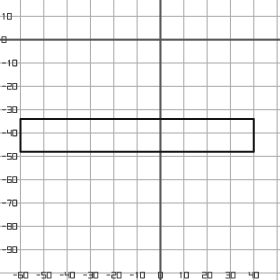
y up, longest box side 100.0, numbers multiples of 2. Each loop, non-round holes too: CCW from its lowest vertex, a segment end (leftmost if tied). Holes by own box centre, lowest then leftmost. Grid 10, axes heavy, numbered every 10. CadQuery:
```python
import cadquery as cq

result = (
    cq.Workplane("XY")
    .moveTo(-60.0, -48.0)
    .lineTo(40.0, -48.0)
    .lineTo(40.0, -34.0)
    .lineTo(-60.0, -34.0)
    .close()
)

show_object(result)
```